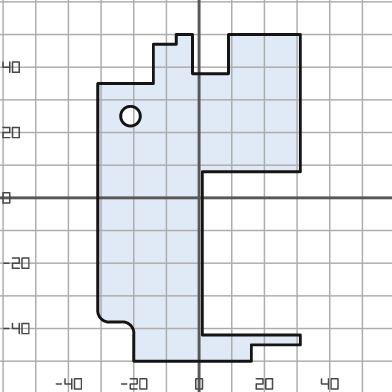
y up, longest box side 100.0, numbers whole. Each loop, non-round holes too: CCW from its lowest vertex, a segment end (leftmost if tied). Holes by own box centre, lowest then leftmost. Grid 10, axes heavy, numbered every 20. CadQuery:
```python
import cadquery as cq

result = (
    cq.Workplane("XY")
    .moveTo(-20.0, -50.0)
    .lineTo(16.0, -50.0)
    .lineTo(16.0, -45.0)
    .lineTo(31.0, -45.0)
    .lineTo(31.0, -42.0)
    .lineTo(1.0, -42.0)
    .lineTo(1.0, 8.0)
    .lineTo(31.0, 8.0)
    .lineTo(31.0, 50.0)
    .lineTo(9.0, 50.0)
    .lineTo(9.0, 38.0)
    .lineTo(-2.0, 38.0)
    .lineTo(-2.0, 50.0)
    .lineTo(-7.0, 50.0)
    .lineTo(-7.0, 47.0)
    .lineTo(-14.0, 47.0)
    .lineTo(-14.0, 35.0)
    .lineTo(-31.0, 35.0)
    .lineTo(-31.0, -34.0)
    .threePointArc((-30.0, -37.0), (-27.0, -38.0))
    .lineTo(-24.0, -38.0)
    .threePointArc((-21.0, -39.0), (-20.0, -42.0))
    .close()
    .moveTo(-21.0, 25.0)
    .circle(3.0)
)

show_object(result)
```